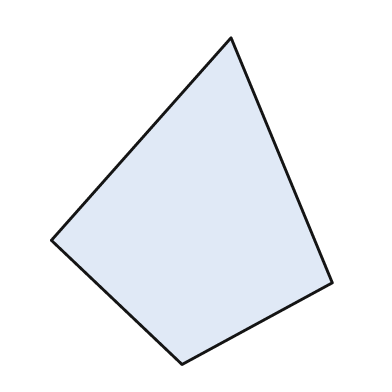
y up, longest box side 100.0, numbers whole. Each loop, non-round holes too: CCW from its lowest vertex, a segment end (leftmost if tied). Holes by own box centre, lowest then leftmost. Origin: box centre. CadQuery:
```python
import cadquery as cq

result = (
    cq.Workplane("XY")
    .moveTo(-3.0, -50.0)
    .lineTo(43.0, -25.0)
    .lineTo(12.0, 50.0)
    .lineTo(-43.0, -12.0)
    .close()
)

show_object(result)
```